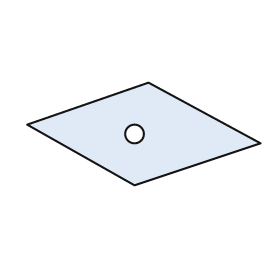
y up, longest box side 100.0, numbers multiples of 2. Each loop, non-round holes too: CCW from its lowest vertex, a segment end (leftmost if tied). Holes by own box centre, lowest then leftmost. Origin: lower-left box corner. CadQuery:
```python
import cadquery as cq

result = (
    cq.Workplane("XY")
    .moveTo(46.0, 0.0)
    .lineTo(100.0, 18.0)
    .lineTo(52.0, 44.0)
    .lineTo(0.0, 26.0)
    .close()
    .moveTo(46.0, 22.0)
    .circle(4.0)
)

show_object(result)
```